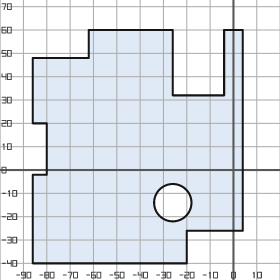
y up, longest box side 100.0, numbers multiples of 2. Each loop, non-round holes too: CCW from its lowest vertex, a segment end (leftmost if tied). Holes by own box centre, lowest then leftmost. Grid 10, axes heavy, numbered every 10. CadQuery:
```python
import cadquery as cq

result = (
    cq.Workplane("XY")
    .moveTo(-86.0, -40.0)
    .lineTo(-20.0, -40.0)
    .lineTo(-20.0, -26.0)
    .lineTo(4.0, -26.0)
    .lineTo(4.0, 60.0)
    .lineTo(-4.0, 60.0)
    .lineTo(-4.0, 32.0)
    .lineTo(-26.0, 32.0)
    .lineTo(-26.0, 60.0)
    .lineTo(-62.0, 60.0)
    .lineTo(-62.0, 48.0)
    .lineTo(-86.0, 48.0)
    .lineTo(-86.0, 20.0)
    .lineTo(-80.0, 20.0)
    .lineTo(-80.0, -2.0)
    .lineTo(-86.0, -2.0)
    .close()
    .moveTo(-26.0, -14.0)
    .circle(8.0)
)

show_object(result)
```